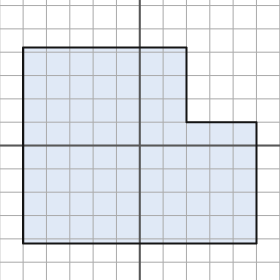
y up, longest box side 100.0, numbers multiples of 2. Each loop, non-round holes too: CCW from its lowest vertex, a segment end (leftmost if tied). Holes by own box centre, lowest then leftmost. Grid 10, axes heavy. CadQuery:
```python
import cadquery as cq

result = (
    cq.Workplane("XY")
    .moveTo(-50.0, -42.0)
    .lineTo(50.0, -42.0)
    .lineTo(50.0, 10.0)
    .lineTo(20.0, 10.0)
    .lineTo(20.0, 42.0)
    .lineTo(-50.0, 42.0)
    .close()
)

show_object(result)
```